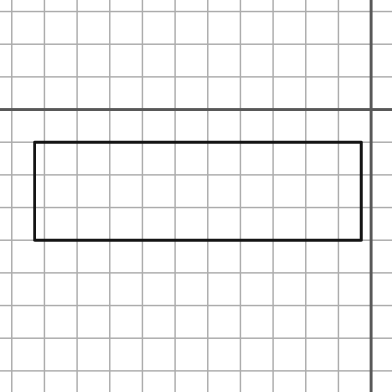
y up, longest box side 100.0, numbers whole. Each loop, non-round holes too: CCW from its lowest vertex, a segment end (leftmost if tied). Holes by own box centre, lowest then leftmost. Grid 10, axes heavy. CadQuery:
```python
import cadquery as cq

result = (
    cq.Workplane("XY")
    .moveTo(-103.0, -40.0)
    .lineTo(-3.0, -40.0)
    .lineTo(-3.0, -10.0)
    .lineTo(-103.0, -10.0)
    .close()
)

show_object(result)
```